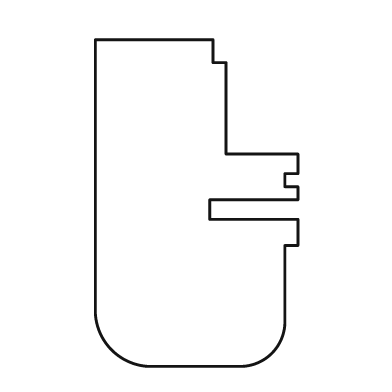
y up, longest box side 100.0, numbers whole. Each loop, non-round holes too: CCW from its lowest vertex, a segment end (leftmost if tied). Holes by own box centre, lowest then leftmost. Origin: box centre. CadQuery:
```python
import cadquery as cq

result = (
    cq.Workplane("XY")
    .moveTo(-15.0, -50.0)
    .lineTo(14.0, -50.0)
    .threePointArc((23.0, -46.0), (27.0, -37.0))
    .lineTo(27.0, -13.0)
    .lineTo(31.0, -13.0)
    .lineTo(31.0, -5.0)
    .lineTo(4.0, -5.0)
    .lineTo(4.0, 1.0)
    .lineTo(31.0, 1.0)
    .lineTo(31.0, 5.0)
    .lineTo(27.0, 5.0)
    .lineTo(27.0, 9.0)
    .lineTo(31.0, 9.0)
    .lineTo(31.0, 15.0)
    .lineTo(9.0, 15.0)
    .lineTo(9.0, 43.0)
    .lineTo(5.0, 43.0)
    .lineTo(5.0, 50.0)
    .lineTo(-31.0, 50.0)
    .lineTo(-31.0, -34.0)
    .threePointArc((-26.0, -45.0), (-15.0, -50.0))
    .close()
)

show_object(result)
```